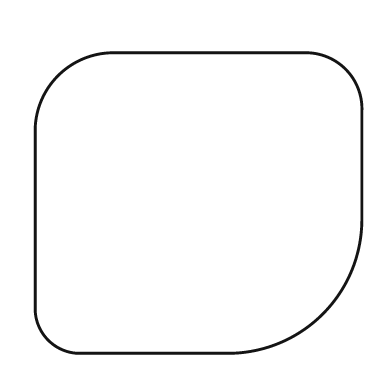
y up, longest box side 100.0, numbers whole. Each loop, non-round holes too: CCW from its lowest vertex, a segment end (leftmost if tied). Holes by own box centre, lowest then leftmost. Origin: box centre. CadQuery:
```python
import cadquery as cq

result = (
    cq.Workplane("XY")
    .moveTo(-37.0, -46.0)
    .lineTo(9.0, -46.0)
    .threePointArc((38.0, -34.0), (50.0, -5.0))
    .lineTo(50.0, 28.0)
    .threePointArc((45.0, 41.0), (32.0, 46.0))
    .lineTo(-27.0, 46.0)
    .threePointArc((-43.0, 39.0), (-50.0, 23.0))
    .lineTo(-50.0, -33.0)
    .threePointArc((-46.0, -42.0), (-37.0, -46.0))
    .close()
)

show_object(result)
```